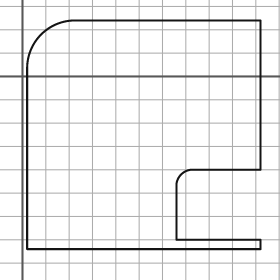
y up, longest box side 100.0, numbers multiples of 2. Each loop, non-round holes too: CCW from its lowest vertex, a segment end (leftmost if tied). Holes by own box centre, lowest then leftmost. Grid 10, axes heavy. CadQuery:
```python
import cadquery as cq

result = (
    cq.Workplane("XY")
    .moveTo(2.0, -74.0)
    .lineTo(102.0, -74.0)
    .lineTo(102.0, -70.0)
    .lineTo(66.0, -70.0)
    .lineTo(66.0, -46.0)
    .threePointArc((68.0, -42.0), (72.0, -40.0))
    .lineTo(102.0, -40.0)
    .lineTo(102.0, 24.0)
    .lineTo(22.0, 24.0)
    .threePointArc((8.0, 18.0), (2.0, 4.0))
    .close()
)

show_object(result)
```